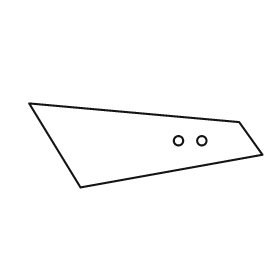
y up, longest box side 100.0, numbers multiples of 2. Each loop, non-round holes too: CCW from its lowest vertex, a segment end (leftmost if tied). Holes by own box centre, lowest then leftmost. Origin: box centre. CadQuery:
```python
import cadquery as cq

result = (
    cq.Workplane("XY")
    .moveTo(-28.0, -18.0)
    .lineTo(50.0, -4.0)
    .lineTo(40.0, 10.0)
    .lineTo(-50.0, 18.0)
    .close()
    .moveTo(14.0, 2.0)
    .circle(2.0)
    .moveTo(24.0, 2.0)
    .circle(2.0)
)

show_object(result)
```